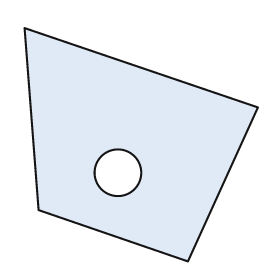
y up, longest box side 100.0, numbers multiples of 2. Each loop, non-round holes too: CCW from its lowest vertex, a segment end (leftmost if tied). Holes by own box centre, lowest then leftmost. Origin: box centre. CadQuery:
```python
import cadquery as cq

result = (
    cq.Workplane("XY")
    .moveTo(20.0, -50.0)
    .lineTo(50.0, 16.0)
    .lineTo(-50.0, 50.0)
    .lineTo(-44.0, -28.0)
    .close()
    .moveTo(-10.0, -12.0)
    .circle(10.0)
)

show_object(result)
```